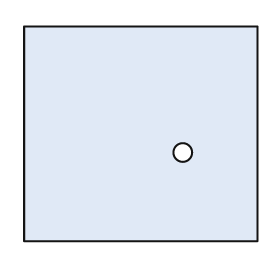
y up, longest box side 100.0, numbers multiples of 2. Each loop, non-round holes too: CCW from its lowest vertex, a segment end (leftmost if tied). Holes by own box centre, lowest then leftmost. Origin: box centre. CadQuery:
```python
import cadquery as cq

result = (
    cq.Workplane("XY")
    .moveTo(-50.0, -46.0)
    .lineTo(50.0, -46.0)
    .lineTo(50.0, 46.0)
    .lineTo(-50.0, 46.0)
    .close()
    .moveTo(18.0, -8.0)
    .circle(4.0)
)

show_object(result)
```